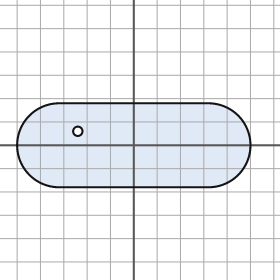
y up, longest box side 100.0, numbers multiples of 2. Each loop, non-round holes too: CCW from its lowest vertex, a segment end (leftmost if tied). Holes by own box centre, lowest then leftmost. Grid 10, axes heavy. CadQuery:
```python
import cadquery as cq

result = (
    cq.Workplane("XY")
    .moveTo(-32.0, -18.0)
    .lineTo(32.0, -18.0)
    .threePointArc((50.0, 0.0), (32.0, 18.0))
    .lineTo(-32.0, 18.0)
    .threePointArc((-50.0, 0.0), (-32.0, -18.0))
    .close()
    .moveTo(-24.0, 6.0)
    .circle(2.0)
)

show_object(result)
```